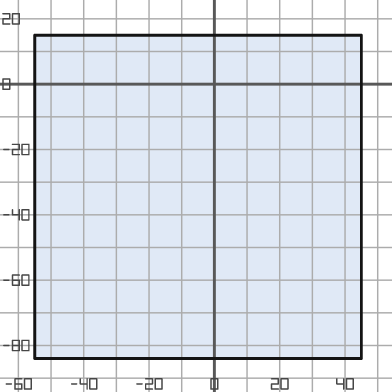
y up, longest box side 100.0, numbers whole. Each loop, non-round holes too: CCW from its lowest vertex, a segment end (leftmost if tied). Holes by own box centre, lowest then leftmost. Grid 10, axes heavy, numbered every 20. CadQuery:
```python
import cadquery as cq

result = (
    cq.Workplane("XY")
    .moveTo(-55.0, -84.0)
    .lineTo(45.0, -84.0)
    .lineTo(45.0, 15.0)
    .lineTo(-55.0, 15.0)
    .close()
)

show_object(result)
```